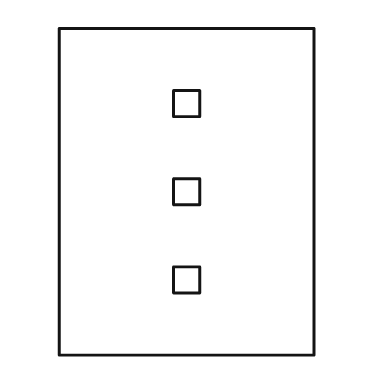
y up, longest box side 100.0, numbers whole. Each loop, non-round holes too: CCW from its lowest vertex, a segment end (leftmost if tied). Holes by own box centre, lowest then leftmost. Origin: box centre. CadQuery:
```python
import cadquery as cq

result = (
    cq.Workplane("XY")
    .moveTo(-39.0, -50.0)
    .lineTo(39.0, -50.0)
    .lineTo(39.0, 50.0)
    .lineTo(-39.0, 50.0)
    .close()
    .moveTo(-4.0, -31.0)
    .lineTo(4.0, -31.0)
    .lineTo(4.0, -23.0)
    .lineTo(-4.0, -23.0)
    .close()
    .moveTo(-4.0, -4.0)
    .lineTo(4.0, -4.0)
    .lineTo(4.0, 4.0)
    .lineTo(-4.0, 4.0)
    .close()
    .moveTo(-4.0, 23.0)
    .lineTo(4.0, 23.0)
    .lineTo(4.0, 31.0)
    .lineTo(-4.0, 31.0)
    .close()
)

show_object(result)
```